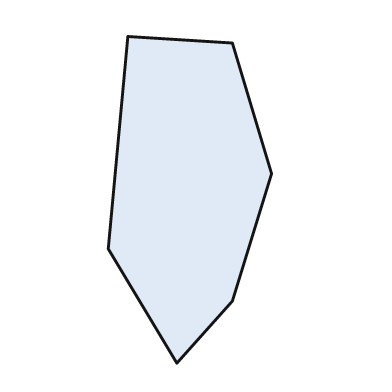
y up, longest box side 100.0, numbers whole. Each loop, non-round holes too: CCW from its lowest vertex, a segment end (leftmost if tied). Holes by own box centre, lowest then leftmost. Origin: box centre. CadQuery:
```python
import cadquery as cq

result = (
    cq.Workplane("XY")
    .moveTo(-4.0, -50.0)
    .lineTo(13.0, -31.0)
    .lineTo(25.0, 8.0)
    .lineTo(13.0, 48.0)
    .lineTo(-19.0, 50.0)
    .lineTo(-25.0, -15.0)
    .close()
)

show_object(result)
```